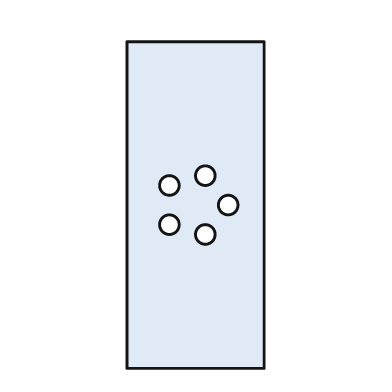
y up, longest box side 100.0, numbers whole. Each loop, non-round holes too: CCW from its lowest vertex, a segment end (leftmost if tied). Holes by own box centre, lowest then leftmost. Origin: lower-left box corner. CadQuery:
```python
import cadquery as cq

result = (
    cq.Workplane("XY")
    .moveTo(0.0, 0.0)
    .lineTo(42.0, 0.0)
    .lineTo(42.0, 100.0)
    .lineTo(0.0, 100.0)
    .close()
    .moveTo(24.0, 41.0)
    .circle(3.0)
    .moveTo(13.0, 44.0)
    .circle(3.0)
    .moveTo(31.0, 50.0)
    .circle(3.0)
    .moveTo(13.0, 56.0)
    .circle(3.0)
    .moveTo(24.0, 59.0)
    .circle(3.0)
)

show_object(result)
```